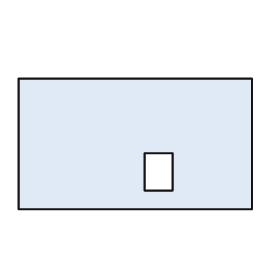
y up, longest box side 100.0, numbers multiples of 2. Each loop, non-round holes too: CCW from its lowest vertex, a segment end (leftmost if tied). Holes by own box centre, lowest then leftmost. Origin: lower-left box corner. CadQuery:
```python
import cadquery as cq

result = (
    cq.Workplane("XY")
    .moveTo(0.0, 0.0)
    .lineTo(100.0, 0.0)
    .lineTo(100.0, 56.0)
    .lineTo(0.0, 56.0)
    .close()
    .moveTo(54.0, 8.0)
    .lineTo(66.0, 8.0)
    .lineTo(66.0, 24.0)
    .lineTo(54.0, 24.0)
    .close()
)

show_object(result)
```